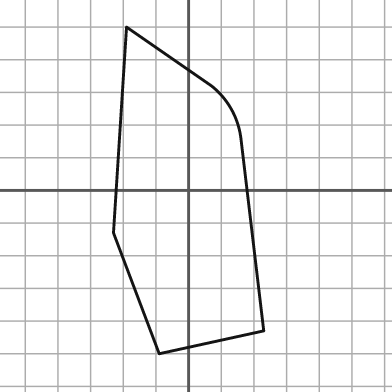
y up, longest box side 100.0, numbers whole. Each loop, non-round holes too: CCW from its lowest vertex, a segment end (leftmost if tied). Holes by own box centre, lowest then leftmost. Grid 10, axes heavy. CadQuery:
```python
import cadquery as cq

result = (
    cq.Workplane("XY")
    .moveTo(-9.0, -50.0)
    .lineTo(23.0, -43.0)
    .lineTo(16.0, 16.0)
    .threePointArc((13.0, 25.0), (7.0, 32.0))
    .lineTo(-19.0, 50.0)
    .lineTo(-23.0, -13.0)
    .close()
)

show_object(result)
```